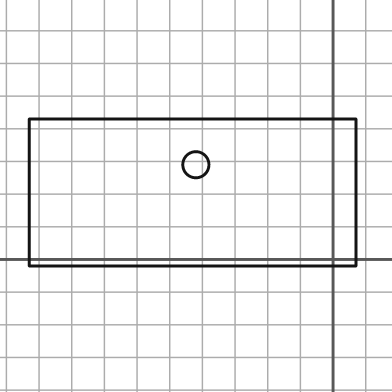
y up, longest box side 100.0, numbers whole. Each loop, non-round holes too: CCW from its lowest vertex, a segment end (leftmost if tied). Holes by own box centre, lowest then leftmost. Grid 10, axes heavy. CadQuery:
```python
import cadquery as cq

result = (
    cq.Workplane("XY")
    .moveTo(-93.0, -2.0)
    .lineTo(7.0, -2.0)
    .lineTo(7.0, 43.0)
    .lineTo(-93.0, 43.0)
    .close()
    .moveTo(-42.0, 29.0)
    .circle(4.0)
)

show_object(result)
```